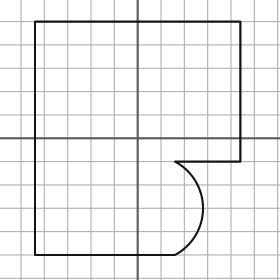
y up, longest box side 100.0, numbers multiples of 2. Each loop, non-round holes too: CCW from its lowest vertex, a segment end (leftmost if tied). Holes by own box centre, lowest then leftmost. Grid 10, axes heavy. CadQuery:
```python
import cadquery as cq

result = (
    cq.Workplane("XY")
    .moveTo(-44.0, -50.0)
    .lineTo(16.0, -50.0)
    .threePointArc((28.0, -30.0), (16.0, -10.0))
    .lineTo(44.0, -10.0)
    .lineTo(44.0, 50.0)
    .lineTo(-44.0, 50.0)
    .close()
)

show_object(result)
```